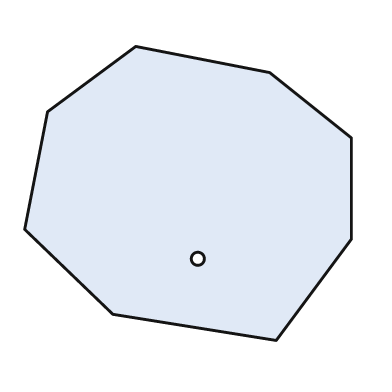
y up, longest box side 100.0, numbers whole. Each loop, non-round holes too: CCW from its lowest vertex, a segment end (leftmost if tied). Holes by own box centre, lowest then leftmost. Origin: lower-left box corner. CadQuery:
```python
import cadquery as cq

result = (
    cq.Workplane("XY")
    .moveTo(77.0, 0.0)
    .lineTo(100.0, 31.0)
    .lineTo(100.0, 62.0)
    .lineTo(75.0, 82.0)
    .lineTo(34.0, 90.0)
    .lineTo(7.0, 70.0)
    .lineTo(0.0, 34.0)
    .lineTo(27.0, 8.0)
    .close()
    .moveTo(53.0, 25.0)
    .circle(2.0)
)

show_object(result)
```